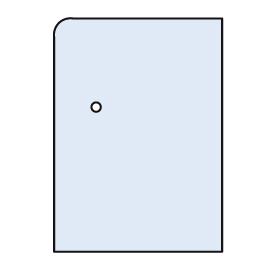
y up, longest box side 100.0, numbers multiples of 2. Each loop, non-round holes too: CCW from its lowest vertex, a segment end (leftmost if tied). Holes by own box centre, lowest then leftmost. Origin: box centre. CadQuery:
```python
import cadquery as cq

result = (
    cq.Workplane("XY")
    .moveTo(-36.0, -50.0)
    .lineTo(36.0, -50.0)
    .lineTo(36.0, 50.0)
    .lineTo(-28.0, 50.0)
    .threePointArc((-34.0, 48.0), (-36.0, 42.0))
    .close()
    .moveTo(-18.0, 12.0)
    .circle(2.0)
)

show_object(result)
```